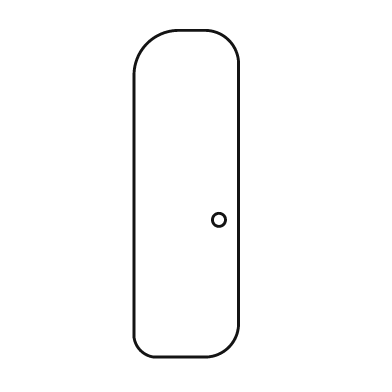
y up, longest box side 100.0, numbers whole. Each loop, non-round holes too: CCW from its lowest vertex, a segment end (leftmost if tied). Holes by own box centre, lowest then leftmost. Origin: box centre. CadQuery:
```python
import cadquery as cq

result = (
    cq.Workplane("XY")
    .moveTo(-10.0, -50.0)
    .lineTo(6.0, -50.0)
    .threePointArc((13.0, -47.0), (16.0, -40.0))
    .lineTo(16.0, 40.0)
    .threePointArc((13.0, 47.0), (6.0, 50.0))
    .lineTo(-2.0, 50.0)
    .threePointArc((-12.0, 46.0), (-16.0, 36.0))
    .lineTo(-16.0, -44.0)
    .threePointArc((-14.0, -48.0), (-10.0, -50.0))
    .close()
    .moveTo(10.0, -8.0)
    .circle(2.0)
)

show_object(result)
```